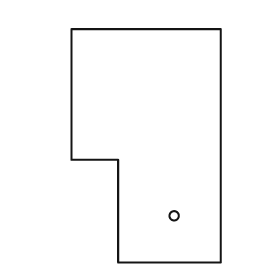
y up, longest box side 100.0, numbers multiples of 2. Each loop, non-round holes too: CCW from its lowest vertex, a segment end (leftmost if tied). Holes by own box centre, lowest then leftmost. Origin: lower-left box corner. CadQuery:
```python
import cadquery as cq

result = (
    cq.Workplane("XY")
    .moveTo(20.0, 0.0)
    .lineTo(64.0, 0.0)
    .lineTo(64.0, 100.0)
    .lineTo(0.0, 100.0)
    .lineTo(0.0, 44.0)
    .lineTo(20.0, 44.0)
    .close()
    .moveTo(44.0, 20.0)
    .circle(2.0)
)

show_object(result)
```